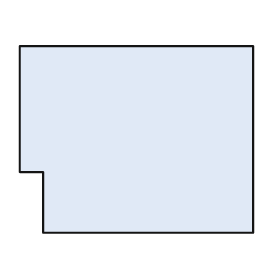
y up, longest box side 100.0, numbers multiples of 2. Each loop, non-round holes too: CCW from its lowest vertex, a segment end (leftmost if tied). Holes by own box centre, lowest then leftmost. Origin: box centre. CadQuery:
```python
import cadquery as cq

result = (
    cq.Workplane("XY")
    .moveTo(-40.0, -40.0)
    .lineTo(50.0, -40.0)
    .lineTo(50.0, 40.0)
    .lineTo(-50.0, 40.0)
    .lineTo(-50.0, -14.0)
    .lineTo(-40.0, -14.0)
    .close()
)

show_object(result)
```